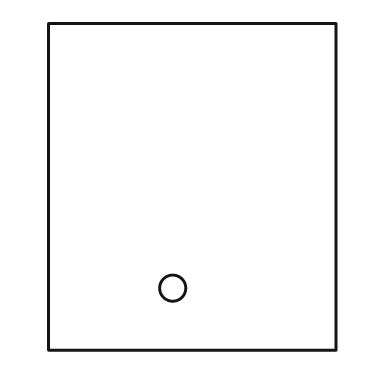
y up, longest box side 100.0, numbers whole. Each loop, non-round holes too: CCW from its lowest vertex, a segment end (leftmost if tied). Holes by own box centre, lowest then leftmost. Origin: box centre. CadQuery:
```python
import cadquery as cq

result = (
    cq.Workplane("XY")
    .moveTo(-44.0, -50.0)
    .lineTo(44.0, -50.0)
    .lineTo(44.0, 50.0)
    .lineTo(-44.0, 50.0)
    .close()
    .moveTo(-6.0, -31.0)
    .circle(4.0)
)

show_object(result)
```